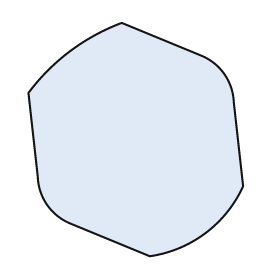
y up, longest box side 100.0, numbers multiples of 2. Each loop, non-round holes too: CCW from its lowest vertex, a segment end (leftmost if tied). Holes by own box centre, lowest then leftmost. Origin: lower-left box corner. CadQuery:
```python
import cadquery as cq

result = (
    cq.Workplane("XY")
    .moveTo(52.0, 0.0)
    .threePointArc((76.0, 10.0), (92.0, 30.0))
    .lineTo(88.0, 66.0)
    .threePointArc((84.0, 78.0), (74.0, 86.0))
    .lineTo(40.0, 100.0)
    .threePointArc((18.0, 88.0), (0.0, 70.0))
    .lineTo(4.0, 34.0)
    .threePointArc((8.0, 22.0), (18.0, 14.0))
    .close()
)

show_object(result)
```